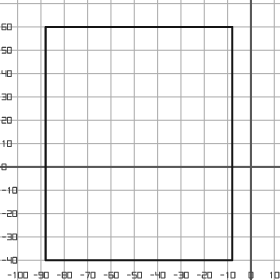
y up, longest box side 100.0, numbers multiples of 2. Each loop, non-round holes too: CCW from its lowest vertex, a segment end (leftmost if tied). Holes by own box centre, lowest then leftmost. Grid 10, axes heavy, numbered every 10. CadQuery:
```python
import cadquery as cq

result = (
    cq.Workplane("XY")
    .moveTo(-88.0, -40.0)
    .lineTo(-8.0, -40.0)
    .lineTo(-8.0, 60.0)
    .lineTo(-88.0, 60.0)
    .close()
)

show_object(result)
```